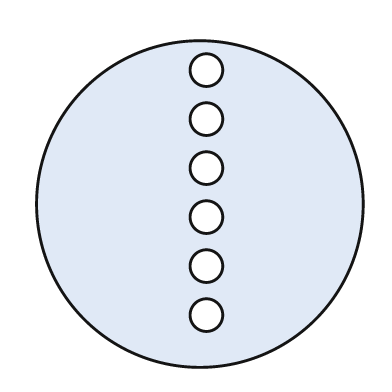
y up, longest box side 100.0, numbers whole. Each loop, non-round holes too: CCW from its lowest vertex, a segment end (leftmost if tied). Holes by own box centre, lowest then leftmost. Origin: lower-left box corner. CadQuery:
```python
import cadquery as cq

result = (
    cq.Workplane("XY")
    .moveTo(50.0, 50.0)
    .circle(50.0)
    .moveTo(52.0, 16.0)
    .circle(5.0)
    .moveTo(52.0, 31.0)
    .circle(5.0)
    .moveTo(52.0, 46.0)
    .circle(5.0)
    .moveTo(52.0, 61.0)
    .circle(5.0)
    .moveTo(52.0, 76.0)
    .circle(5.0)
    .moveTo(52.0, 91.0)
    .circle(5.0)
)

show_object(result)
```